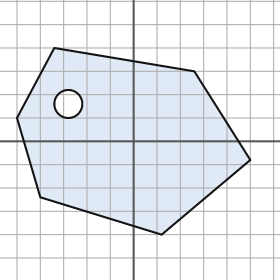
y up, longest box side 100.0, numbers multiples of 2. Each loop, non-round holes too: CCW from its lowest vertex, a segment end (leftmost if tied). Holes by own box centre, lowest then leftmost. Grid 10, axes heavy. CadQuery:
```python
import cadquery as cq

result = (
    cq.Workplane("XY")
    .moveTo(12.0, -40.0)
    .lineTo(50.0, -8.0)
    .lineTo(26.0, 30.0)
    .lineTo(-34.0, 40.0)
    .lineTo(-50.0, 10.0)
    .lineTo(-40.0, -24.0)
    .close()
    .moveTo(-28.0, 16.0)
    .circle(6.0)
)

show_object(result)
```